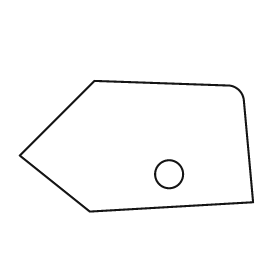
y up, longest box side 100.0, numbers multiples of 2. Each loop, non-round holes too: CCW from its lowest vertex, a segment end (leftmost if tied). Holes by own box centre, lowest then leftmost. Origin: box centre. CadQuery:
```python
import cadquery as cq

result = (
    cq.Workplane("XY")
    .moveTo(-20.0, -28.0)
    .lineTo(50.0, -24.0)
    .lineTo(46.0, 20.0)
    .threePointArc((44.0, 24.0), (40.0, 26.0))
    .lineTo(-18.0, 28.0)
    .lineTo(-50.0, -4.0)
    .close()
    .moveTo(14.0, -12.0)
    .circle(6.0)
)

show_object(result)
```